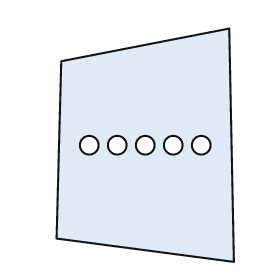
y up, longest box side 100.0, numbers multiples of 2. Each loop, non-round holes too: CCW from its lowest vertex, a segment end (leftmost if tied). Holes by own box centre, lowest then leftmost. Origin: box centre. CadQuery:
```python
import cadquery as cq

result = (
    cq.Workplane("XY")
    .moveTo(38.0, -50.0)
    .lineTo(36.0, 50.0)
    .lineTo(-36.0, 36.0)
    .lineTo(-38.0, -40.0)
    .close()
    .moveTo(-24.0, 0.0)
    .circle(4.0)
    .moveTo(-12.0, 0.0)
    .circle(4.0)
    .moveTo(0.0, 0.0)
    .circle(4.0)
    .moveTo(12.0, 0.0)
    .circle(4.0)
    .moveTo(24.0, 0.0)
    .circle(4.0)
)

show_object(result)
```